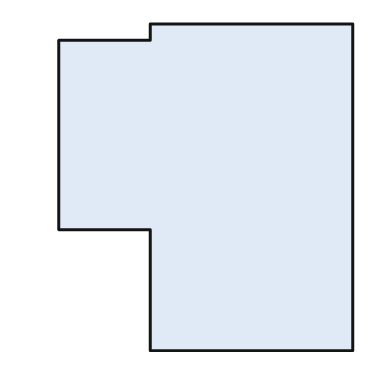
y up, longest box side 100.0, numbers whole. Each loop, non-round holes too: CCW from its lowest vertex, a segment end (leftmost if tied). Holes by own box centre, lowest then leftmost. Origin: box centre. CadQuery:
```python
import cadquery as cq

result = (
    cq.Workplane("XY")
    .moveTo(-17.0, -50.0)
    .lineTo(45.0, -50.0)
    .lineTo(45.0, 50.0)
    .lineTo(-17.0, 50.0)
    .lineTo(-17.0, 45.0)
    .lineTo(-45.0, 45.0)
    .lineTo(-45.0, -13.0)
    .lineTo(-17.0, -13.0)
    .close()
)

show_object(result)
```